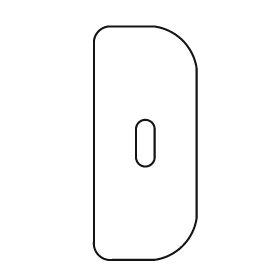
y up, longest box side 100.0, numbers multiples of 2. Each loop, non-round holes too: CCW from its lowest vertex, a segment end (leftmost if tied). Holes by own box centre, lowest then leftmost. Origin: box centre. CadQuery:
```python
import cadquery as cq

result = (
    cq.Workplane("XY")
    .moveTo(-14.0, -50.0)
    .lineTo(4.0, -50.0)
    .threePointArc((16.0, -44.0), (22.0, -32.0))
    .lineTo(22.0, 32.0)
    .threePointArc((16.0, 44.0), (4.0, 50.0))
    .lineTo(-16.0, 50.0)
    .threePointArc((-20.0, 48.0), (-22.0, 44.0))
    .lineTo(-22.0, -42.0)
    .threePointArc((-20.0, -48.0), (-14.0, -50.0))
    .close()
    .moveTo(-4.0, -6.0)
    .threePointArc((0.0, -10.0), (4.0, -6.0))
    .lineTo(4.0, 6.0)
    .threePointArc((0.0, 10.0), (-4.0, 6.0))
    .close()
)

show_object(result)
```